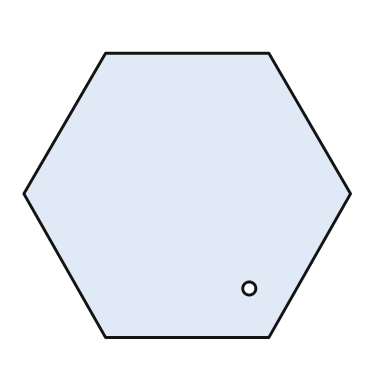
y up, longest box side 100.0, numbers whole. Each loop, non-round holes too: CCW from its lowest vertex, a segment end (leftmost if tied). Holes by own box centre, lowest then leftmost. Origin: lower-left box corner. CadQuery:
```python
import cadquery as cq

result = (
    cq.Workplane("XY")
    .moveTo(25.0, 0.0)
    .lineTo(75.0, 0.0)
    .lineTo(100.0, 44.0)
    .lineTo(75.0, 87.0)
    .lineTo(25.0, 87.0)
    .lineTo(0.0, 44.0)
    .close()
    .moveTo(69.0, 15.0)
    .circle(2.0)
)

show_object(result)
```